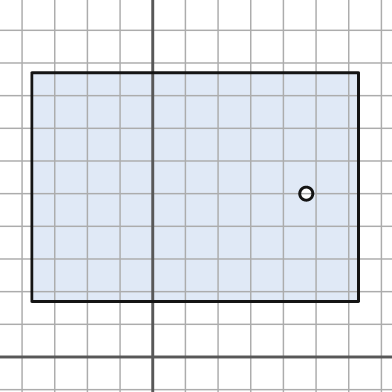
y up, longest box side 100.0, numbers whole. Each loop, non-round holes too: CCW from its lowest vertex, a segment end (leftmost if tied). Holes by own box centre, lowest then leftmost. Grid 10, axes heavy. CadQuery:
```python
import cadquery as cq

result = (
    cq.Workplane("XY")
    .moveTo(-37.0, 17.0)
    .lineTo(63.0, 17.0)
    .lineTo(63.0, 87.0)
    .lineTo(-37.0, 87.0)
    .close()
    .moveTo(47.0, 50.0)
    .circle(2.0)
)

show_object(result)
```